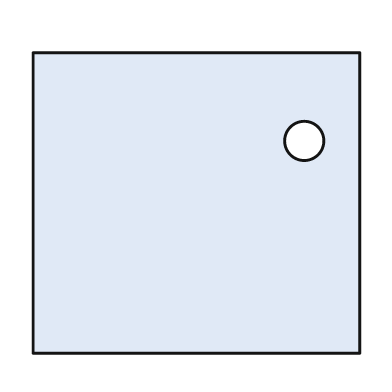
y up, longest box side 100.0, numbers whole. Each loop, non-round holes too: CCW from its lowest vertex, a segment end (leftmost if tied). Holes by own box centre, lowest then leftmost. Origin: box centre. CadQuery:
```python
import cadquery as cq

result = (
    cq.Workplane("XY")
    .moveTo(-50.0, -46.0)
    .lineTo(50.0, -46.0)
    .lineTo(50.0, 46.0)
    .lineTo(-50.0, 46.0)
    .close()
    .moveTo(33.0, 19.0)
    .circle(6.0)
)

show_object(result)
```